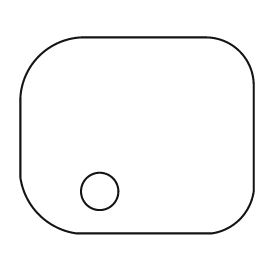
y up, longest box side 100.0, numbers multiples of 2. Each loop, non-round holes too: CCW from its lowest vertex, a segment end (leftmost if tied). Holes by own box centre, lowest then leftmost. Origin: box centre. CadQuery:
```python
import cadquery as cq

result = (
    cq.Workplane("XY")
    .moveTo(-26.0, -42.0)
    .lineTo(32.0, -42.0)
    .threePointArc((44.0, -36.0), (50.0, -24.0))
    .lineTo(50.0, 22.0)
    .threePointArc((44.0, 36.0), (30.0, 42.0))
    .lineTo(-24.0, 42.0)
    .threePointArc((-42.0, 34.0), (-50.0, 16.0))
    .lineTo(-50.0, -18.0)
    .threePointArc((-42.0, -34.0), (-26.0, -42.0))
    .close()
    .moveTo(-16.0, -24.0)
    .circle(8.0)
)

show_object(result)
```